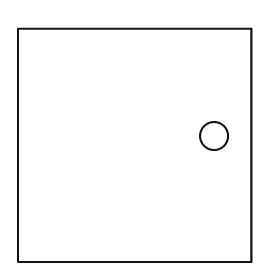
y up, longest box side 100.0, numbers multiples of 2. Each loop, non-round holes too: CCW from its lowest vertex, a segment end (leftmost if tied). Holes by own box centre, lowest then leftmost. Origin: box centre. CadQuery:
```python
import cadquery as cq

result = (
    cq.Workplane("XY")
    .moveTo(-50.0, -50.0)
    .lineTo(50.0, -50.0)
    .lineTo(50.0, 50.0)
    .lineTo(-50.0, 50.0)
    .close()
    .moveTo(34.0, 4.0)
    .circle(6.0)
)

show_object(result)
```